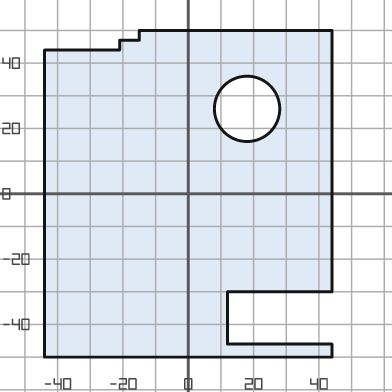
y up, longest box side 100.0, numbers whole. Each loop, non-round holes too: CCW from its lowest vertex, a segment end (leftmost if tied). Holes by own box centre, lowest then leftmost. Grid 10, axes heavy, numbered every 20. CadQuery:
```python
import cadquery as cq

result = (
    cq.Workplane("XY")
    .moveTo(-44.0, -50.0)
    .lineTo(44.0, -50.0)
    .lineTo(44.0, -46.0)
    .lineTo(12.0, -46.0)
    .lineTo(12.0, -30.0)
    .lineTo(44.0, -30.0)
    .lineTo(44.0, 50.0)
    .lineTo(-15.0, 50.0)
    .lineTo(-15.0, 47.0)
    .lineTo(-21.0, 47.0)
    .lineTo(-21.0, 44.0)
    .lineTo(-44.0, 44.0)
    .close()
    .moveTo(18.0, 26.0)
    .circle(10.0)
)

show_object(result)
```